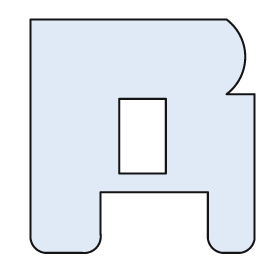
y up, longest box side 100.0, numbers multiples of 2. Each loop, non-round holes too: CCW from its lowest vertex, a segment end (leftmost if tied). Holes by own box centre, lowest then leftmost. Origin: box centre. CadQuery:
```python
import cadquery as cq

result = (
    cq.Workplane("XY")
    .moveTo(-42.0, -50.0)
    .lineTo(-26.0, -50.0)
    .threePointArc((-20.0, -48.0), (-18.0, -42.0))
    .lineTo(-18.0, -24.0)
    .lineTo(28.0, -24.0)
    .lineTo(28.0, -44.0)
    .threePointArc((30.0, -48.0), (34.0, -50.0))
    .lineTo(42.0, -50.0)
    .threePointArc((46.0, -48.0), (48.0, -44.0))
    .lineTo(48.0, 18.0)
    .lineTo(36.0, 18.0)
    .threePointArc((44.0, 34.0), (36.0, 50.0))
    .lineTo(-48.0, 50.0)
    .lineTo(-48.0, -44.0)
    .threePointArc((-46.0, -48.0), (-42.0, -50.0))
    .close()
    .moveTo(-10.0, -16.0)
    .lineTo(10.0, -16.0)
    .lineTo(10.0, 16.0)
    .lineTo(-10.0, 16.0)
    .close()
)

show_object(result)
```